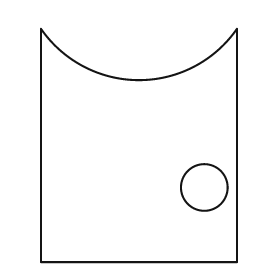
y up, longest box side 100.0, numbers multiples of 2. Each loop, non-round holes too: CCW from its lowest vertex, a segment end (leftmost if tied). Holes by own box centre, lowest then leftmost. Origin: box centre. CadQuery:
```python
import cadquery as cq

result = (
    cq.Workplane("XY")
    .moveTo(-42.0, -50.0)
    .lineTo(42.0, -50.0)
    .lineTo(42.0, 50.0)
    .threePointArc((0.0, 28.0), (-42.0, 50.0))
    .close()
    .moveTo(28.0, -18.0)
    .circle(10.0)
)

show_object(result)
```